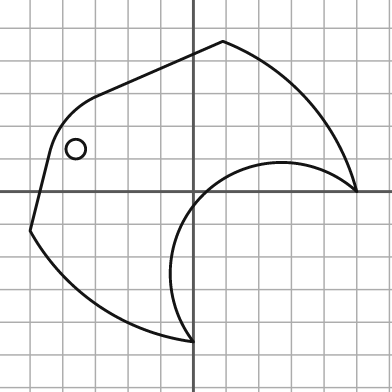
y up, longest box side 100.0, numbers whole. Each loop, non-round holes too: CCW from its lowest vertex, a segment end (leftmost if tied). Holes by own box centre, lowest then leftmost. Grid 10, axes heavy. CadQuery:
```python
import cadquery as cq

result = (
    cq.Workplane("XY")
    .moveTo(0.0, -46.0)
    .threePointArc((4.0, 0.0), (50.0, 0.0))
    .threePointArc((35.0, 28.0), (9.0, 46.0))
    .lineTo(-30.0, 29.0)
    .threePointArc((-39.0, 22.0), (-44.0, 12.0))
    .lineTo(-50.0, -12.0)
    .threePointArc((-29.0, -35.0), (0.0, -46.0))
    .close()
    .moveTo(-36.0, 13.0)
    .circle(3.0)
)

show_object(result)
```